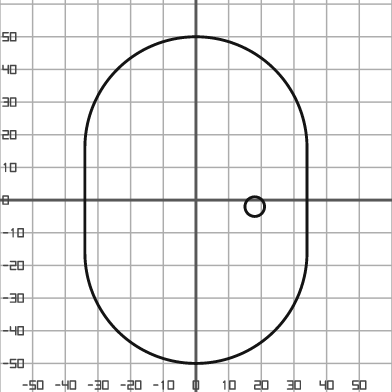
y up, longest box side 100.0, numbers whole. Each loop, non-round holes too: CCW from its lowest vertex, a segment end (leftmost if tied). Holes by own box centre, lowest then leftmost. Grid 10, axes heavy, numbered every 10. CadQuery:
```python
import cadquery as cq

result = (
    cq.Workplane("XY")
    .moveTo(-34.0, -16.0)
    .threePointArc((0.0, -50.0), (34.0, -16.0))
    .lineTo(34.0, 16.0)
    .threePointArc((0.0, 50.0), (-34.0, 16.0))
    .close()
    .moveTo(18.0, -2.0)
    .circle(3.0)
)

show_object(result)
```